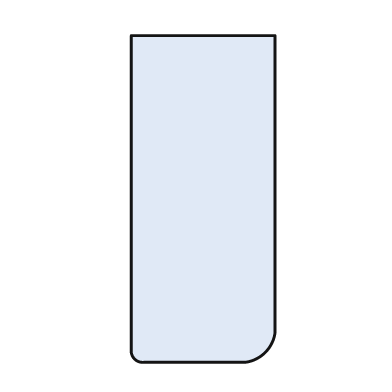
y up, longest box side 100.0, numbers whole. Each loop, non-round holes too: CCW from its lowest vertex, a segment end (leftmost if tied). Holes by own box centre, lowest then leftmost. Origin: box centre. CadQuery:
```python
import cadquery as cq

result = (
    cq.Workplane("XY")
    .moveTo(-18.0, -50.0)
    .lineTo(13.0, -50.0)
    .threePointArc((19.0, -47.0), (22.0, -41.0))
    .lineTo(22.0, 50.0)
    .lineTo(-22.0, 50.0)
    .lineTo(-22.0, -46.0)
    .threePointArc((-21.0, -49.0), (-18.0, -50.0))
    .close()
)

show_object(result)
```